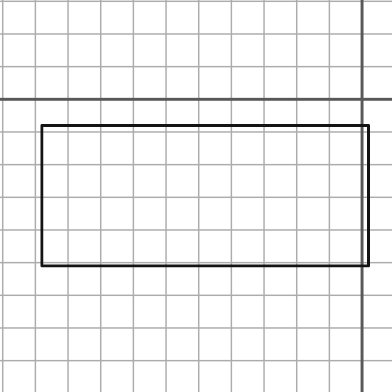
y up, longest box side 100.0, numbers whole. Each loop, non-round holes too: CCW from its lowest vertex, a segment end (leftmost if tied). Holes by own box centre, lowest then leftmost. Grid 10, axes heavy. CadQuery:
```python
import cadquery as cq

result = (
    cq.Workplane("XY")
    .moveTo(-98.0, -51.0)
    .lineTo(2.0, -51.0)
    .lineTo(2.0, -8.0)
    .lineTo(-98.0, -8.0)
    .close()
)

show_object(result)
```